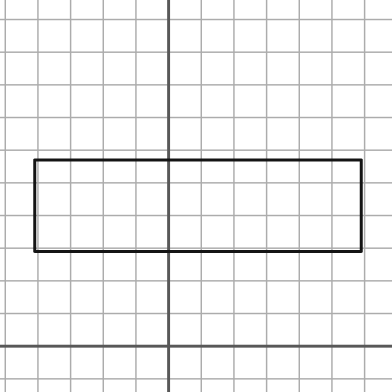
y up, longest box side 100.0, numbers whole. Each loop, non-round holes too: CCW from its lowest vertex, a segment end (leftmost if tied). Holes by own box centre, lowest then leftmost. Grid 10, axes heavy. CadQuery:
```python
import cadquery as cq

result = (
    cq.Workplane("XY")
    .moveTo(-41.0, 29.0)
    .lineTo(59.0, 29.0)
    .lineTo(59.0, 57.0)
    .lineTo(-41.0, 57.0)
    .close()
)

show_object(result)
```